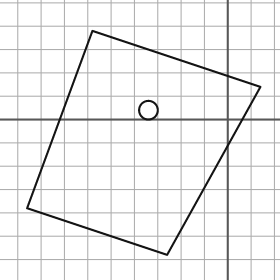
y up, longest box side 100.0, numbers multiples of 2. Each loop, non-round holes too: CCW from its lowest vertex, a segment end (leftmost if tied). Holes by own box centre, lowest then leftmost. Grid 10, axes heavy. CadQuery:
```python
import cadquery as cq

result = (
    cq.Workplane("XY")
    .moveTo(-26.0, -58.0)
    .lineTo(14.0, 14.0)
    .lineTo(-58.0, 38.0)
    .lineTo(-86.0, -38.0)
    .close()
    .moveTo(-34.0, 4.0)
    .circle(4.0)
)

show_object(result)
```